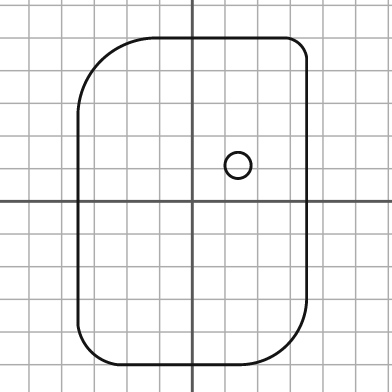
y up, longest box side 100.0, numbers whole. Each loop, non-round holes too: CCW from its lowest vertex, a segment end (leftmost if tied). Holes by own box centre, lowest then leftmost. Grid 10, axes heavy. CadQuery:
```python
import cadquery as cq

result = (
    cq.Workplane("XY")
    .moveTo(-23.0, -50.0)
    .lineTo(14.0, -50.0)
    .threePointArc((29.0, -44.0), (35.0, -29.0))
    .lineTo(35.0, 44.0)
    .threePointArc((33.0, 48.0), (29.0, 50.0))
    .lineTo(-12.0, 50.0)
    .threePointArc((-28.0, 43.0), (-35.0, 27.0))
    .lineTo(-35.0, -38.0)
    .threePointArc((-31.0, -46.0), (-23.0, -50.0))
    .close()
    .moveTo(14.0, 11.0)
    .circle(4.0)
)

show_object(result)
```